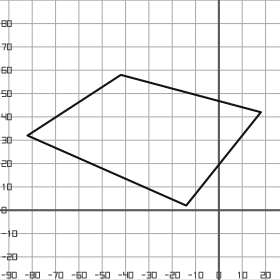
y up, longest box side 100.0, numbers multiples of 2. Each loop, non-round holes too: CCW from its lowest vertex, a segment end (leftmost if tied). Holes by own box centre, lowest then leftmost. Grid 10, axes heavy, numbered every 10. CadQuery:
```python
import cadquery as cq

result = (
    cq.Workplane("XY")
    .moveTo(-14.0, 2.0)
    .lineTo(18.0, 42.0)
    .lineTo(-42.0, 58.0)
    .lineTo(-82.0, 32.0)
    .close()
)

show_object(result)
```